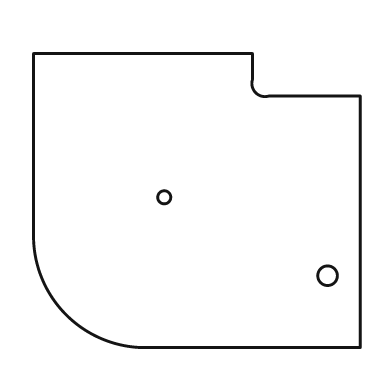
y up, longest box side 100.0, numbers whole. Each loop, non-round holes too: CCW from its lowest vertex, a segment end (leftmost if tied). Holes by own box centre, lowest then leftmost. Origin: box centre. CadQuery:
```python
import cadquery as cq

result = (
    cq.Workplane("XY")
    .moveTo(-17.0, -45.0)
    .lineTo(50.0, -45.0)
    .lineTo(50.0, 32.0)
    .lineTo(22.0, 32.0)
    .threePointArc((18.0, 33.0), (17.0, 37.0))
    .lineTo(17.0, 45.0)
    .lineTo(-50.0, 45.0)
    .lineTo(-50.0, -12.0)
    .threePointArc((-40.0, -35.0), (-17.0, -45.0))
    .close()
    .moveTo(40.0, -23.0)
    .circle(3.0)
    .moveTo(-10.0, 1.0)
    .circle(2.0)
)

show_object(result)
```